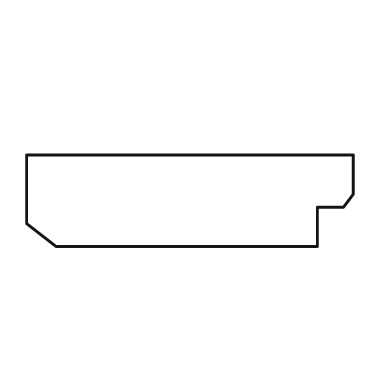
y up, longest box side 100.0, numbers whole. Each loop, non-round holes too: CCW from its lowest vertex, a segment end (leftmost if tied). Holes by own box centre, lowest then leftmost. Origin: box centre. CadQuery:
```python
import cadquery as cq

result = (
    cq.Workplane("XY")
    .moveTo(-41.0, -14.0)
    .lineTo(39.0, -14.0)
    .lineTo(39.0, -2.0)
    .lineTo(47.0, -2.0)
    .lineTo(50.0, 2.0)
    .lineTo(50.0, 14.0)
    .lineTo(-50.0, 14.0)
    .lineTo(-50.0, -7.0)
    .close()
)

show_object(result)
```